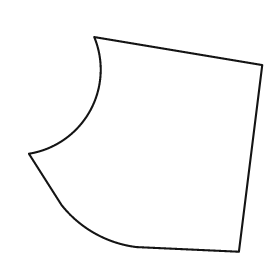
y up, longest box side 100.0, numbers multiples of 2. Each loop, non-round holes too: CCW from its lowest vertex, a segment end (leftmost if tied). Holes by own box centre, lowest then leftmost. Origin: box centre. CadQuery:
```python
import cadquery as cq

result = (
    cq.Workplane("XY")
    .moveTo(40.0, -46.0)
    .lineTo(50.0, 34.0)
    .lineTo(-22.0, 46.0)
    .threePointArc((-24.0, 14.0), (-50.0, -4.0))
    .lineTo(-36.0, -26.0)
    .threePointArc((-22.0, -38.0), (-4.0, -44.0))
    .close()
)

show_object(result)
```